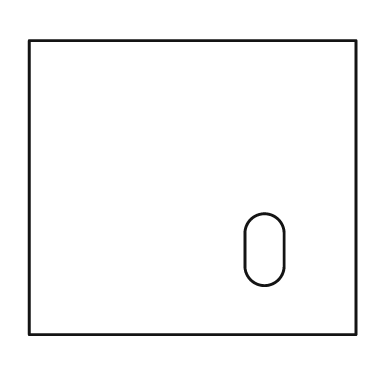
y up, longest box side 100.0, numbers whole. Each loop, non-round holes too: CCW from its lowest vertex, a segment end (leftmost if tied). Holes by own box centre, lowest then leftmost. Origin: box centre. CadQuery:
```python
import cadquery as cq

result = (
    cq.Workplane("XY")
    .moveTo(-50.0, -45.0)
    .lineTo(50.0, -45.0)
    .lineTo(50.0, 45.0)
    .lineTo(-50.0, 45.0)
    .close()
    .moveTo(16.0, -24.0)
    .threePointArc((22.0, -30.0), (28.0, -24.0))
    .lineTo(28.0, -14.0)
    .threePointArc((22.0, -8.0), (16.0, -14.0))
    .close()
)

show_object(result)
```